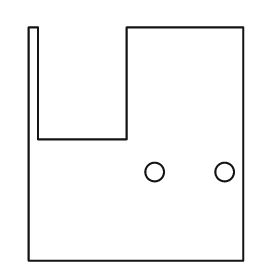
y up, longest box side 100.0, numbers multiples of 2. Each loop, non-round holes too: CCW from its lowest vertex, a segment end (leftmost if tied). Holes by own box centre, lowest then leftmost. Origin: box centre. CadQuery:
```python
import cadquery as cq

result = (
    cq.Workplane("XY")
    .moveTo(-46.0, -50.0)
    .lineTo(46.0, -50.0)
    .lineTo(46.0, 50.0)
    .lineTo(-4.0, 50.0)
    .lineTo(-4.0, 2.0)
    .lineTo(-42.0, 2.0)
    .lineTo(-42.0, 50.0)
    .lineTo(-46.0, 50.0)
    .close()
    .moveTo(8.0, -12.0)
    .circle(4.0)
    .moveTo(38.0, -12.0)
    .circle(4.0)
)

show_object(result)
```